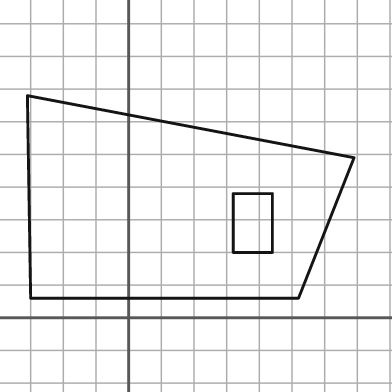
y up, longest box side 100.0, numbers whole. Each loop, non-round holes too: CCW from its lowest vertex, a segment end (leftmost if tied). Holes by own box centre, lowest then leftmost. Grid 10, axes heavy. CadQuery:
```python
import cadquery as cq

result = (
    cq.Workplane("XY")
    .moveTo(-30.0, 6.0)
    .lineTo(52.0, 6.0)
    .lineTo(69.0, 49.0)
    .lineTo(-31.0, 68.0)
    .close()
    .moveTo(32.0, 20.0)
    .lineTo(44.0, 20.0)
    .lineTo(44.0, 38.0)
    .lineTo(32.0, 38.0)
    .close()
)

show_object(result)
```